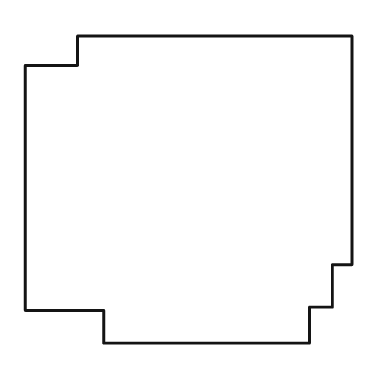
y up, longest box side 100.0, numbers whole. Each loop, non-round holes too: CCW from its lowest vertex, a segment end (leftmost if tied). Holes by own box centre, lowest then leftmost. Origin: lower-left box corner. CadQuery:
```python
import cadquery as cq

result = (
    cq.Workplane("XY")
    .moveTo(24.0, 0.0)
    .lineTo(87.0, 0.0)
    .lineTo(87.0, 11.0)
    .lineTo(94.0, 11.0)
    .lineTo(94.0, 24.0)
    .lineTo(100.0, 24.0)
    .lineTo(100.0, 94.0)
    .lineTo(16.0, 94.0)
    .lineTo(16.0, 85.0)
    .lineTo(0.0, 85.0)
    .lineTo(0.0, 10.0)
    .lineTo(24.0, 10.0)
    .close()
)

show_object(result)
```